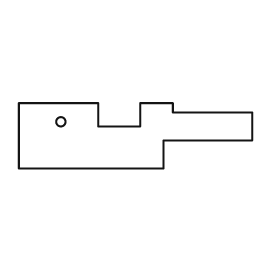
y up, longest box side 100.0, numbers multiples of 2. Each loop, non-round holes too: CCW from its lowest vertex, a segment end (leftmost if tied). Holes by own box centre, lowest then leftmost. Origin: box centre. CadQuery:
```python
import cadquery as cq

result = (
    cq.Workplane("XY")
    .moveTo(-50.0, -14.0)
    .lineTo(12.0, -14.0)
    .lineTo(12.0, -2.0)
    .lineTo(50.0, -2.0)
    .lineTo(50.0, 10.0)
    .lineTo(16.0, 10.0)
    .lineTo(16.0, 14.0)
    .lineTo(2.0, 14.0)
    .lineTo(2.0, 4.0)
    .lineTo(-16.0, 4.0)
    .lineTo(-16.0, 14.0)
    .lineTo(-50.0, 14.0)
    .close()
    .moveTo(-32.0, 6.0)
    .circle(2.0)
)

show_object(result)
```